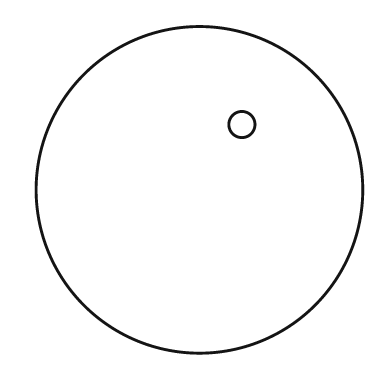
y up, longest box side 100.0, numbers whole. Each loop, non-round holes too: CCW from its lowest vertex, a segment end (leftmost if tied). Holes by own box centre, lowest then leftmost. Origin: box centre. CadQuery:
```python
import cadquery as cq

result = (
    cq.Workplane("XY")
    .moveTo(0.0, 0.0)
    .circle(50.0)
    .moveTo(13.0, 20.0)
    .circle(4.0)
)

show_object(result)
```